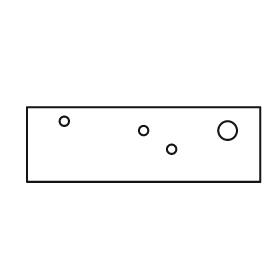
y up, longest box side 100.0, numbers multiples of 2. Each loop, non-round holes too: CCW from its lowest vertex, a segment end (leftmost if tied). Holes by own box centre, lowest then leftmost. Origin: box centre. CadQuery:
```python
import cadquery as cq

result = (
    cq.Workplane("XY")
    .moveTo(-50.0, -16.0)
    .lineTo(50.0, -16.0)
    .lineTo(50.0, 16.0)
    .lineTo(-50.0, 16.0)
    .close()
    .moveTo(12.0, -2.0)
    .circle(2.0)
    .moveTo(0.0, 6.0)
    .circle(2.0)
    .moveTo(36.0, 6.0)
    .circle(4.0)
    .moveTo(-34.0, 10.0)
    .circle(2.0)
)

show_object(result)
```